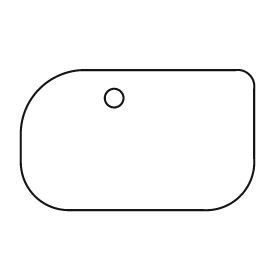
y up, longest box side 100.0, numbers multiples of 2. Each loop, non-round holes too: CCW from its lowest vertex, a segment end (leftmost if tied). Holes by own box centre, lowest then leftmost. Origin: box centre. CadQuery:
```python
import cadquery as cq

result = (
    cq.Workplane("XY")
    .moveTo(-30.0, -30.0)
    .lineTo(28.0, -30.0)
    .threePointArc((44.0, -24.0), (50.0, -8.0))
    .lineTo(50.0, 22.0)
    .threePointArc((48.0, 28.0), (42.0, 30.0))
    .lineTo(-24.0, 30.0)
    .threePointArc((-42.0, 22.0), (-50.0, 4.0))
    .lineTo(-50.0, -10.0)
    .threePointArc((-44.0, -24.0), (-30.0, -30.0))
    .close()
    .moveTo(-10.0, 18.0)
    .circle(4.0)
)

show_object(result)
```